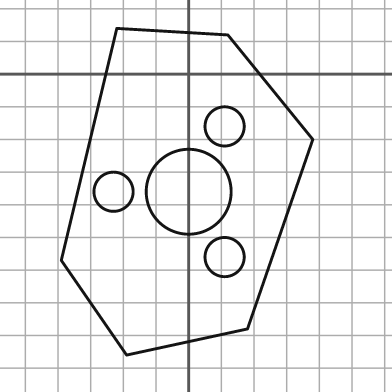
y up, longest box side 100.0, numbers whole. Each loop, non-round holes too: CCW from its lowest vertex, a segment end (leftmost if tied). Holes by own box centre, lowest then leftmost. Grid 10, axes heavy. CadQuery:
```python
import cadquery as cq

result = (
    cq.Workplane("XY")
    .moveTo(-19.0, -86.0)
    .lineTo(18.0, -78.0)
    .lineTo(38.0, -20.0)
    .lineTo(12.0, 12.0)
    .lineTo(-22.0, 14.0)
    .lineTo(-39.0, -57.0)
    .close()
    .moveTo(11.0, -56.0)
    .circle(6.0)
    .moveTo(-23.0, -36.0)
    .circle(6.0)
    .moveTo(0.0, -36.0)
    .circle(13.0)
    .moveTo(11.0, -16.0)
    .circle(6.0)
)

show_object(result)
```